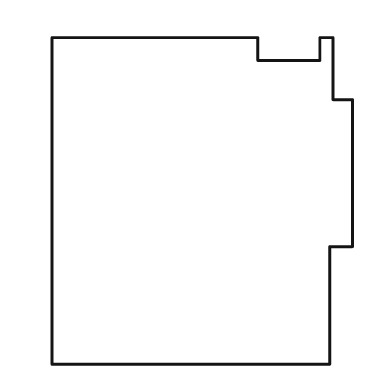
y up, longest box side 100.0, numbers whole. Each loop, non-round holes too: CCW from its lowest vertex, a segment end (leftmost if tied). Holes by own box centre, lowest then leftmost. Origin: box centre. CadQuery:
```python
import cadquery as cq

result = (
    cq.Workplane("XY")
    .moveTo(-46.0, -50.0)
    .lineTo(39.0, -50.0)
    .lineTo(39.0, -14.0)
    .lineTo(46.0, -14.0)
    .lineTo(46.0, 31.0)
    .lineTo(40.0, 31.0)
    .lineTo(40.0, 50.0)
    .lineTo(36.0, 50.0)
    .lineTo(36.0, 43.0)
    .lineTo(17.0, 43.0)
    .lineTo(17.0, 50.0)
    .lineTo(-46.0, 50.0)
    .close()
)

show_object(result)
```